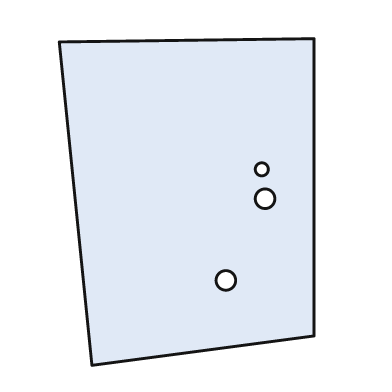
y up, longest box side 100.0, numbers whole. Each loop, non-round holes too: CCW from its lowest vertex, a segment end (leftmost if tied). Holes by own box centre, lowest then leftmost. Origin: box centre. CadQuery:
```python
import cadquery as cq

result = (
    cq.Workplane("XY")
    .moveTo(-29.0, -50.0)
    .lineTo(39.0, -41.0)
    .lineTo(39.0, 50.0)
    .lineTo(-39.0, 49.0)
    .close()
    .moveTo(12.0, -24.0)
    .circle(3.0)
    .moveTo(24.0, 1.0)
    .circle(3.0)
    .moveTo(23.0, 10.0)
    .circle(2.0)
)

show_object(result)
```